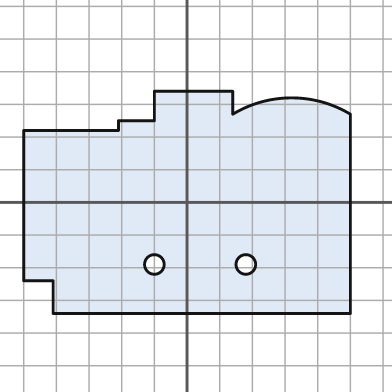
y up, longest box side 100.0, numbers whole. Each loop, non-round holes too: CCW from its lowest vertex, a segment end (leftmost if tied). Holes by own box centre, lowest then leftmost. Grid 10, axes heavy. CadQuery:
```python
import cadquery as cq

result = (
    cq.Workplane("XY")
    .moveTo(-41.0, -34.0)
    .lineTo(50.0, -34.0)
    .lineTo(50.0, 27.0)
    .threePointArc((32.0, 32.0), (14.0, 27.0))
    .lineTo(14.0, 34.0)
    .lineTo(-10.0, 34.0)
    .lineTo(-10.0, 25.0)
    .lineTo(-21.0, 25.0)
    .lineTo(-21.0, 22.0)
    .lineTo(-50.0, 22.0)
    .lineTo(-50.0, -24.0)
    .lineTo(-41.0, -24.0)
    .close()
    .moveTo(-10.0, -19.0)
    .circle(3.0)
    .moveTo(18.0, -19.0)
    .circle(3.0)
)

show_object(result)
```